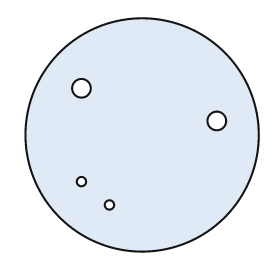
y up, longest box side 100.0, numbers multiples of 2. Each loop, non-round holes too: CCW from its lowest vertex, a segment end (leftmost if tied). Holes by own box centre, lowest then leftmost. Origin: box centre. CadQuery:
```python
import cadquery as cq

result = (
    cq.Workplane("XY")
    .moveTo(0.0, 0.0)
    .circle(50.0)
    .moveTo(-14.0, -30.0)
    .circle(2.0)
    .moveTo(-26.0, -20.0)
    .circle(2.0)
    .moveTo(32.0, 6.0)
    .circle(4.0)
    .moveTo(-26.0, 20.0)
    .circle(4.0)
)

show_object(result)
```